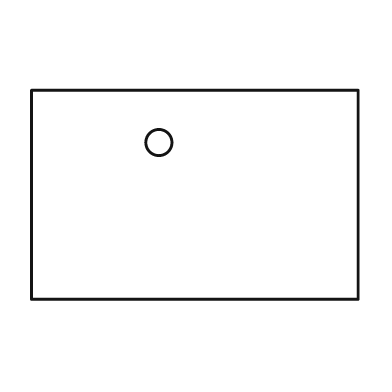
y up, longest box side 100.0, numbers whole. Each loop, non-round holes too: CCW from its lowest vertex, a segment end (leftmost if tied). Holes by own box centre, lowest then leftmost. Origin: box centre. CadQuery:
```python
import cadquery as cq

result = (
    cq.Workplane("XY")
    .moveTo(-50.0, -32.0)
    .lineTo(50.0, -32.0)
    .lineTo(50.0, 32.0)
    .lineTo(-50.0, 32.0)
    .close()
    .moveTo(-11.0, 16.0)
    .circle(4.0)
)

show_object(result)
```